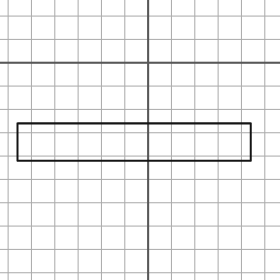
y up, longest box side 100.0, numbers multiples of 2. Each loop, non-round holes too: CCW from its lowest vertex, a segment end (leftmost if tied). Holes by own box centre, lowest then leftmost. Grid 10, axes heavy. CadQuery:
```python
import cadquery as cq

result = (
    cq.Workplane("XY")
    .moveTo(-56.0, -42.0)
    .lineTo(44.0, -42.0)
    .lineTo(44.0, -26.0)
    .lineTo(-56.0, -26.0)
    .close()
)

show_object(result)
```